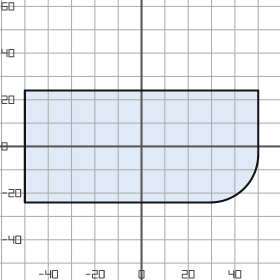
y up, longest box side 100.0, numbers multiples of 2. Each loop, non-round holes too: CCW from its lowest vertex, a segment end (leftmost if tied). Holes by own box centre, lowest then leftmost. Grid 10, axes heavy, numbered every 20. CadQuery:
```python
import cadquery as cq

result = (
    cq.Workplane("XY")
    .moveTo(-50.0, -24.0)
    .lineTo(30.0, -24.0)
    .threePointArc((44.0, -18.0), (50.0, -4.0))
    .lineTo(50.0, 24.0)
    .lineTo(-50.0, 24.0)
    .close()
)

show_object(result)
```